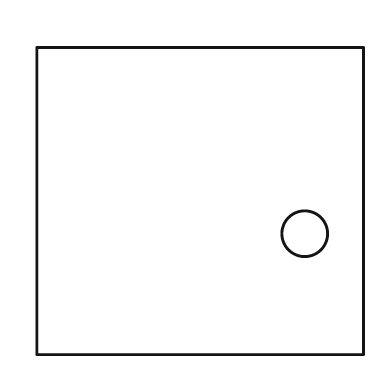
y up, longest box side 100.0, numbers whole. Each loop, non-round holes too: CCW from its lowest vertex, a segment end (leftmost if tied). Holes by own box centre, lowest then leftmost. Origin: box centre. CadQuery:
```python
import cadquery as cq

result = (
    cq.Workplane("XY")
    .moveTo(-50.0, -47.0)
    .lineTo(50.0, -47.0)
    .lineTo(50.0, 47.0)
    .lineTo(-50.0, 47.0)
    .close()
    .moveTo(32.0, -10.0)
    .circle(7.0)
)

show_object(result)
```